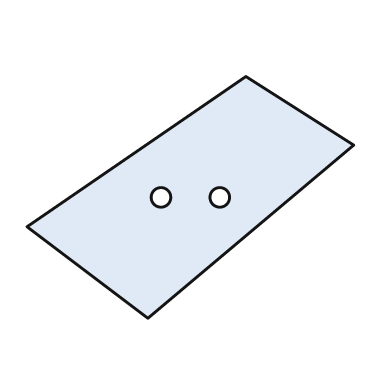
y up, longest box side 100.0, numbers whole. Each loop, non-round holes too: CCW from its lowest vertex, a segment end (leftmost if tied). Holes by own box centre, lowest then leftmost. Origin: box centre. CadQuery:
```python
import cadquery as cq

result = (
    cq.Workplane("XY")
    .moveTo(-13.0, -37.0)
    .lineTo(50.0, 16.0)
    .lineTo(17.0, 37.0)
    .lineTo(-50.0, -9.0)
    .close()
    .moveTo(-9.0, 0.0)
    .circle(3.0)
    .moveTo(9.0, 0.0)
    .circle(3.0)
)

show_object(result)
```